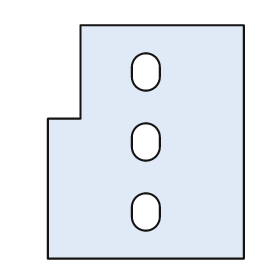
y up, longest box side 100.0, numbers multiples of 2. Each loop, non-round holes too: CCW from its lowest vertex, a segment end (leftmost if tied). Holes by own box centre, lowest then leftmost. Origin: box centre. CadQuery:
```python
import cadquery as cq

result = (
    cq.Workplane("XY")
    .moveTo(-42.0, -50.0)
    .lineTo(42.0, -50.0)
    .lineTo(42.0, 50.0)
    .lineTo(-28.0, 50.0)
    .lineTo(-28.0, 10.0)
    .lineTo(-42.0, 10.0)
    .close()
    .moveTo(-6.0, -32.0)
    .threePointArc((0.0, -38.0), (6.0, -32.0))
    .lineTo(6.0, -28.0)
    .threePointArc((0.0, -22.0), (-6.0, -28.0))
    .close()
    .moveTo(-6.0, -2.0)
    .threePointArc((0.0, -8.0), (6.0, -2.0))
    .lineTo(6.0, 2.0)
    .threePointArc((0.0, 8.0), (-6.0, 2.0))
    .close()
    .moveTo(-6.0, 28.0)
    .threePointArc((0.0, 22.0), (6.0, 28.0))
    .lineTo(6.0, 32.0)
    .threePointArc((0.0, 38.0), (-6.0, 32.0))
    .close()
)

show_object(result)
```